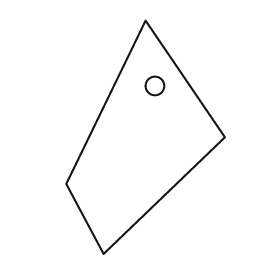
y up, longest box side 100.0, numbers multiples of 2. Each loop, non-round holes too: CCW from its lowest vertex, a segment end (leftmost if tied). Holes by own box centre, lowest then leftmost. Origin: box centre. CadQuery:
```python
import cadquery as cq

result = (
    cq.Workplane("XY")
    .moveTo(-18.0, -50.0)
    .lineTo(34.0, 0.0)
    .lineTo(0.0, 50.0)
    .lineTo(-34.0, -20.0)
    .close()
    .moveTo(4.0, 22.0)
    .circle(4.0)
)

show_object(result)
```